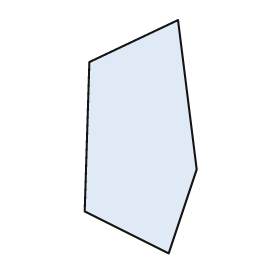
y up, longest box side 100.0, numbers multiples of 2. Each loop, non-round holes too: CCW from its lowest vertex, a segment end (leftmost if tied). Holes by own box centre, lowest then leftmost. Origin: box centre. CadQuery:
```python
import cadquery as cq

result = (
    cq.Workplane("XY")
    .moveTo(12.0, -50.0)
    .lineTo(24.0, -14.0)
    .lineTo(16.0, 50.0)
    .lineTo(-22.0, 32.0)
    .lineTo(-24.0, -32.0)
    .close()
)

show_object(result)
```